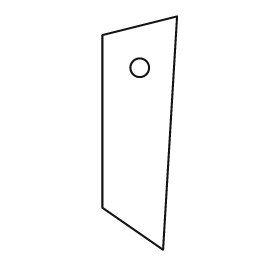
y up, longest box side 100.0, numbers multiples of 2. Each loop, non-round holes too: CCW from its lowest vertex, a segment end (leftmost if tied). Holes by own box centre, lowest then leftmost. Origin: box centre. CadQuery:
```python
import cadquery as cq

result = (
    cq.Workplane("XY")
    .moveTo(10.0, -50.0)
    .lineTo(16.0, 50.0)
    .lineTo(-16.0, 42.0)
    .lineTo(-16.0, -32.0)
    .close()
    .moveTo(0.0, 28.0)
    .circle(4.0)
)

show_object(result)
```